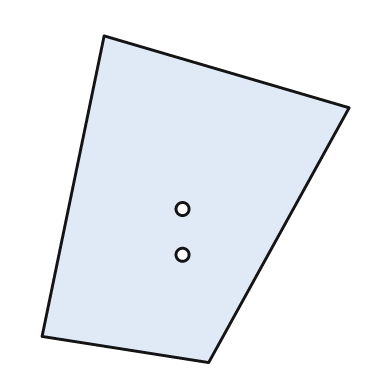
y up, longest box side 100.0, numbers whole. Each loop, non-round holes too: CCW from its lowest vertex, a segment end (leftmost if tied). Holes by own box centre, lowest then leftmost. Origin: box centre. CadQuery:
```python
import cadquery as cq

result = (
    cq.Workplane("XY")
    .moveTo(4.0, -50.0)
    .lineTo(47.0, 28.0)
    .lineTo(-28.0, 50.0)
    .lineTo(-47.0, -42.0)
    .close()
    .moveTo(-4.0, -17.0)
    .circle(2.0)
    .moveTo(-4.0, -3.0)
    .circle(2.0)
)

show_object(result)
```